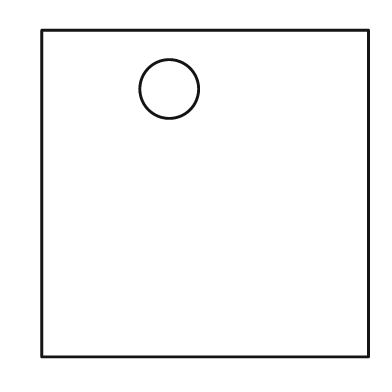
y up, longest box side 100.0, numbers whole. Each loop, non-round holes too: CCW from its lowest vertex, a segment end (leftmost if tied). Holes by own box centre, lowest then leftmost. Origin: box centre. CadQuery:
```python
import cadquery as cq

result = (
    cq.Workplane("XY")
    .moveTo(-50.0, -50.0)
    .lineTo(50.0, -50.0)
    .lineTo(50.0, 50.0)
    .lineTo(-50.0, 50.0)
    .close()
    .moveTo(-11.0, 32.0)
    .circle(9.0)
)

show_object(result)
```